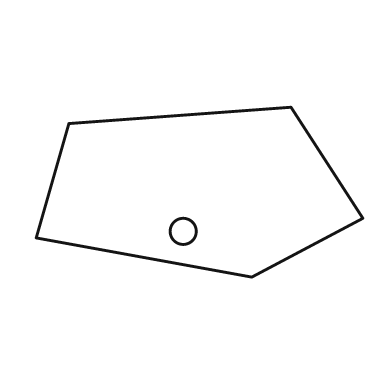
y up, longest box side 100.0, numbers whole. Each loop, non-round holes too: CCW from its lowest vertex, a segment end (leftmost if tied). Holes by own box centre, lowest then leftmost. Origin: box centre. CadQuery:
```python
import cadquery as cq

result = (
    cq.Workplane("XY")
    .moveTo(16.0, -26.0)
    .lineTo(50.0, -8.0)
    .lineTo(28.0, 26.0)
    .lineTo(-40.0, 21.0)
    .lineTo(-50.0, -14.0)
    .close()
    .moveTo(-5.0, -12.0)
    .circle(4.0)
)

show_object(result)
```